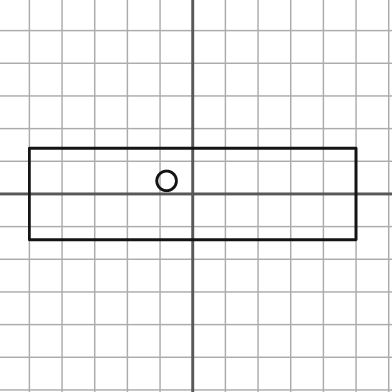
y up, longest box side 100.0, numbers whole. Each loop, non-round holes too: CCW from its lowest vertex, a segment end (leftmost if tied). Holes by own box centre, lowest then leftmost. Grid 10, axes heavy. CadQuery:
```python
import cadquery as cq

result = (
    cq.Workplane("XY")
    .moveTo(-50.0, -14.0)
    .lineTo(50.0, -14.0)
    .lineTo(50.0, 14.0)
    .lineTo(-50.0, 14.0)
    .close()
    .moveTo(-8.0, 4.0)
    .circle(3.0)
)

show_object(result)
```